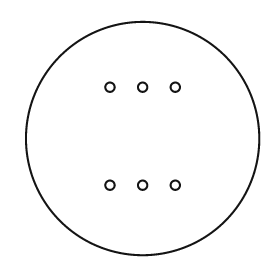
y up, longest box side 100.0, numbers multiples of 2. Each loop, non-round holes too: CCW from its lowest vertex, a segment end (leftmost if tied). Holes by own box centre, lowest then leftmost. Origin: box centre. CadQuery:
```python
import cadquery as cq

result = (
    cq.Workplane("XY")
    .moveTo(0.0, 0.0)
    .circle(50.0)
    .moveTo(-14.0, -20.0)
    .circle(2.0)
    .moveTo(0.0, -20.0)
    .circle(2.0)
    .moveTo(14.0, -20.0)
    .circle(2.0)
    .moveTo(-14.0, 22.0)
    .circle(2.0)
    .moveTo(0.0, 22.0)
    .circle(2.0)
    .moveTo(14.0, 22.0)
    .circle(2.0)
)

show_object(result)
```